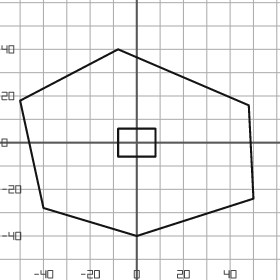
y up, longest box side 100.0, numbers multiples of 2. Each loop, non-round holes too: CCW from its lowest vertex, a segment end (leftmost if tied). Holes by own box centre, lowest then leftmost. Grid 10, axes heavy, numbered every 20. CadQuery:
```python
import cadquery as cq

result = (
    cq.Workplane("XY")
    .moveTo(0.0, -40.0)
    .lineTo(50.0, -24.0)
    .lineTo(48.0, 16.0)
    .lineTo(-8.0, 40.0)
    .lineTo(-50.0, 18.0)
    .lineTo(-40.0, -28.0)
    .close()
    .moveTo(-8.0, -6.0)
    .lineTo(8.0, -6.0)
    .lineTo(8.0, 6.0)
    .lineTo(-8.0, 6.0)
    .close()
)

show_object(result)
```